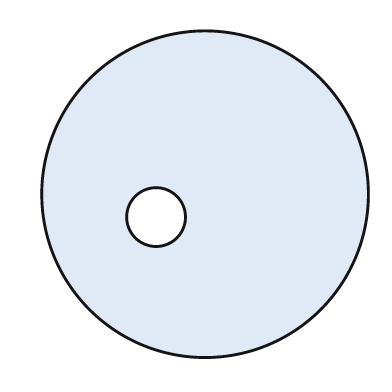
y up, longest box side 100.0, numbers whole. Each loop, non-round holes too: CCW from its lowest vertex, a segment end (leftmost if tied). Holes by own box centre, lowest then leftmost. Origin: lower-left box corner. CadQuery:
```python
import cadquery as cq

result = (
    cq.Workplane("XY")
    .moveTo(50.0, 50.0)
    .circle(50.0)
    .moveTo(35.0, 43.0)
    .circle(9.0)
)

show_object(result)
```